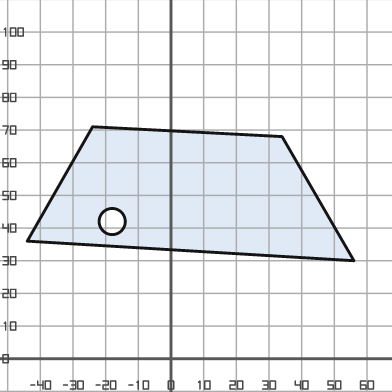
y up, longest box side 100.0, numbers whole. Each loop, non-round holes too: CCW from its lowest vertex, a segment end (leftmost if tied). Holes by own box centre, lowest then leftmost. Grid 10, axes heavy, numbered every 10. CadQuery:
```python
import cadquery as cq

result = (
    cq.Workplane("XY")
    .moveTo(56.0, 30.0)
    .lineTo(34.0, 68.0)
    .lineTo(-24.0, 71.0)
    .lineTo(-44.0, 36.0)
    .close()
    .moveTo(-18.0, 42.0)
    .circle(4.0)
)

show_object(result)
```